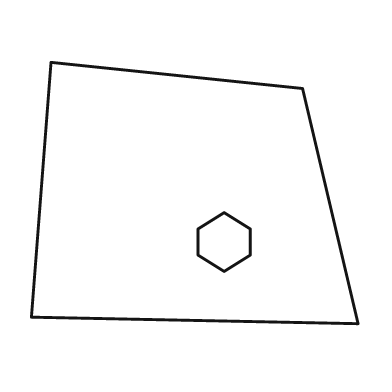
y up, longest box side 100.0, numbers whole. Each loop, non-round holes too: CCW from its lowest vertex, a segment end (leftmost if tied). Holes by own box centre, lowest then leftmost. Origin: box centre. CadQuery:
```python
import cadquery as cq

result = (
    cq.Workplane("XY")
    .moveTo(50.0, -40.0)
    .lineTo(33.0, 32.0)
    .lineTo(-44.0, 40.0)
    .lineTo(-50.0, -38.0)
    .close()
    .moveTo(9.0, -24.0)
    .lineTo(17.0, -19.0)
    .lineTo(17.0, -11.0)
    .lineTo(9.0, -6.0)
    .lineTo(1.0, -11.0)
    .lineTo(1.0, -19.0)
    .close()
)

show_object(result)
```